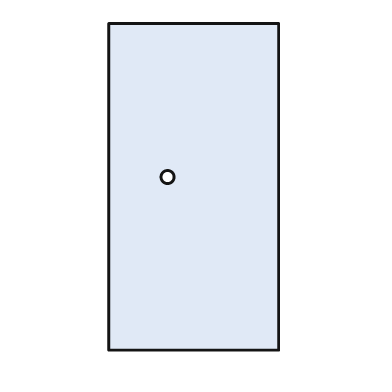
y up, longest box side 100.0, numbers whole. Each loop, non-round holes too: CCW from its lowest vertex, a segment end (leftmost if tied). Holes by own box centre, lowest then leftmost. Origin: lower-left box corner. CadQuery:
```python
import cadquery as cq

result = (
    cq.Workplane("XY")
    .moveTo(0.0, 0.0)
    .lineTo(52.0, 0.0)
    .lineTo(52.0, 100.0)
    .lineTo(0.0, 100.0)
    .close()
    .moveTo(18.0, 53.0)
    .circle(2.0)
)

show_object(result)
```